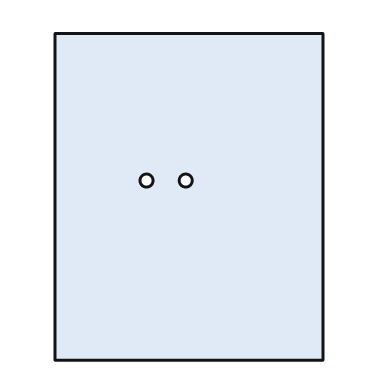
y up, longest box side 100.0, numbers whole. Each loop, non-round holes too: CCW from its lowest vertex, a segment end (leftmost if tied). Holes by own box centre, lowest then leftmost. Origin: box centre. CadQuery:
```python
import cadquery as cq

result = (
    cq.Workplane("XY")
    .moveTo(-41.0, -50.0)
    .lineTo(41.0, -50.0)
    .lineTo(41.0, 50.0)
    .lineTo(-41.0, 50.0)
    .close()
    .moveTo(-13.0, 5.0)
    .circle(2.0)
    .moveTo(-1.0, 5.0)
    .circle(2.0)
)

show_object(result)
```